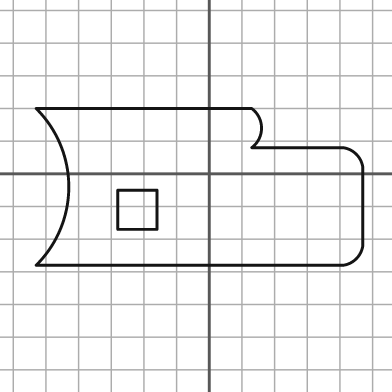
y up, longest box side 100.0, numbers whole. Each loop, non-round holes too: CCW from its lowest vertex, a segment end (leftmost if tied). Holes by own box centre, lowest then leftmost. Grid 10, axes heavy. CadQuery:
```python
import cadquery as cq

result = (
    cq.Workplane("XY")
    .moveTo(-53.0, -28.0)
    .lineTo(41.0, -28.0)
    .threePointArc((45.0, -26.0), (47.0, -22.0))
    .lineTo(47.0, 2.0)
    .threePointArc((45.0, 6.0), (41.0, 8.0))
    .lineTo(13.0, 8.0)
    .threePointArc((16.0, 14.0), (13.0, 20.0))
    .lineTo(-53.0, 20.0)
    .threePointArc((-43.0, -4.0), (-53.0, -28.0))
    .close()
    .moveTo(-28.0, -17.0)
    .lineTo(-16.0, -17.0)
    .lineTo(-16.0, -5.0)
    .lineTo(-28.0, -5.0)
    .close()
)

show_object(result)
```